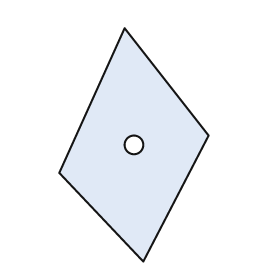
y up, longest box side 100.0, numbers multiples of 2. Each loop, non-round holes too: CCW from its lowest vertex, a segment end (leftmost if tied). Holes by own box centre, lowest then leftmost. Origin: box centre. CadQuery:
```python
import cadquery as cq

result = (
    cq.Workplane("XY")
    .moveTo(4.0, -50.0)
    .lineTo(32.0, 4.0)
    .lineTo(-4.0, 50.0)
    .lineTo(-32.0, -12.0)
    .close()
    .moveTo(0.0, 0.0)
    .circle(4.0)
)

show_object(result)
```